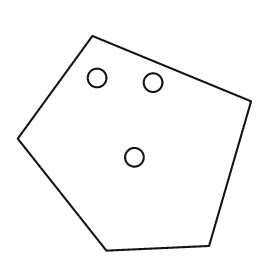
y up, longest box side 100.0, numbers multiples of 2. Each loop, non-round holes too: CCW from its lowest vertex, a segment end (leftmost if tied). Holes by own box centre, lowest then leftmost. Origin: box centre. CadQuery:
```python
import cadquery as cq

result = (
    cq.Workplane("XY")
    .moveTo(-12.0, -46.0)
    .lineTo(32.0, -44.0)
    .lineTo(50.0, 18.0)
    .lineTo(-18.0, 46.0)
    .lineTo(-50.0, 2.0)
    .close()
    .moveTo(0.0, -6.0)
    .circle(4.0)
    .moveTo(8.0, 26.0)
    .circle(4.0)
    .moveTo(-16.0, 28.0)
    .circle(4.0)
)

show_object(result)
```